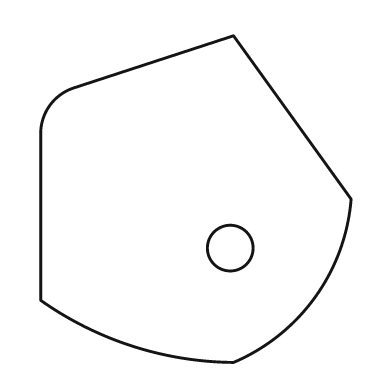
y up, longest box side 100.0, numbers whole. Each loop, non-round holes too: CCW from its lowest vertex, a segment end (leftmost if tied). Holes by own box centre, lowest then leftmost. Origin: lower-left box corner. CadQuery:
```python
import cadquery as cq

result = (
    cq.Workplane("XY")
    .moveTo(59.0, 0.0)
    .threePointArc((84.0, 20.0), (95.0, 50.0))
    .lineTo(59.0, 100.0)
    .lineTo(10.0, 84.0)
    .threePointArc((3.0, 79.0), (0.0, 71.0))
    .lineTo(0.0, 19.0)
    .threePointArc((28.0, 5.0), (59.0, 0.0))
    .close()
    .moveTo(58.0, 35.0)
    .circle(7.0)
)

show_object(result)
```